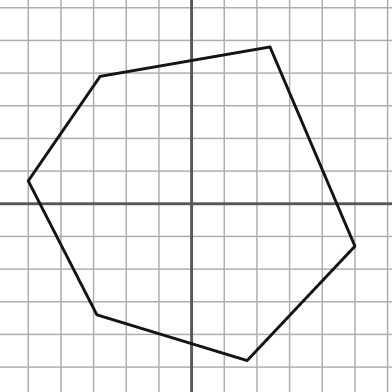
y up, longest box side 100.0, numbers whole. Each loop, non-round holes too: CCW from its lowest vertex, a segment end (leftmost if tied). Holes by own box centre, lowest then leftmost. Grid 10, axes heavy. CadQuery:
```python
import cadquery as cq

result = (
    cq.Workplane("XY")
    .moveTo(17.0, -48.0)
    .lineTo(50.0, -13.0)
    .lineTo(24.0, 48.0)
    .lineTo(-28.0, 39.0)
    .lineTo(-50.0, 7.0)
    .lineTo(-29.0, -34.0)
    .close()
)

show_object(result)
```